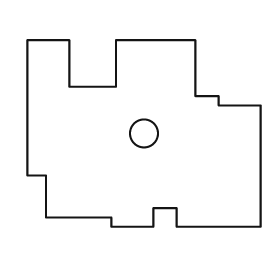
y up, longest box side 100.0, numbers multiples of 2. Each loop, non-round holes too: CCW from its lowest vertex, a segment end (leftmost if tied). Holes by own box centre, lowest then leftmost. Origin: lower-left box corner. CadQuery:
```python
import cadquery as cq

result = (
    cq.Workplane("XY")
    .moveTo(36.0, 0.0)
    .lineTo(54.0, 0.0)
    .lineTo(54.0, 8.0)
    .lineTo(64.0, 8.0)
    .lineTo(64.0, 0.0)
    .lineTo(100.0, 0.0)
    .lineTo(100.0, 52.0)
    .lineTo(82.0, 52.0)
    .lineTo(82.0, 56.0)
    .lineTo(72.0, 56.0)
    .lineTo(72.0, 80.0)
    .lineTo(38.0, 80.0)
    .lineTo(38.0, 60.0)
    .lineTo(18.0, 60.0)
    .lineTo(18.0, 80.0)
    .lineTo(0.0, 80.0)
    .lineTo(0.0, 22.0)
    .lineTo(8.0, 22.0)
    .lineTo(8.0, 4.0)
    .lineTo(36.0, 4.0)
    .close()
    .moveTo(50.0, 40.0)
    .circle(6.0)
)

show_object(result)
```